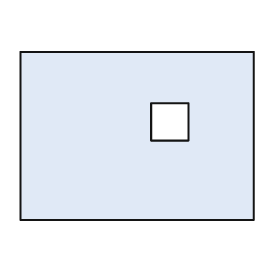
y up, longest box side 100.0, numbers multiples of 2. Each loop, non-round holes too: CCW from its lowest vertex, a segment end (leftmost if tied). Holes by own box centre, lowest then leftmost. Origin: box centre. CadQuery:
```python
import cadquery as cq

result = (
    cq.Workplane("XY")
    .moveTo(-50.0, -36.0)
    .lineTo(50.0, -36.0)
    .lineTo(50.0, 36.0)
    .lineTo(-50.0, 36.0)
    .close()
    .moveTo(6.0, -2.0)
    .lineTo(22.0, -2.0)
    .lineTo(22.0, 14.0)
    .lineTo(6.0, 14.0)
    .close()
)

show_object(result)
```